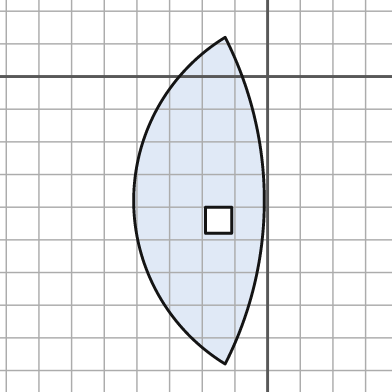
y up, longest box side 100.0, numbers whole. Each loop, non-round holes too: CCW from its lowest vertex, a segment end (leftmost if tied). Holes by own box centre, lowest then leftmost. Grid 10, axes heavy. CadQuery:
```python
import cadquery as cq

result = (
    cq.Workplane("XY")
    .moveTo(-13.0, -88.0)
    .threePointArc((-1.0, -38.0), (-13.0, 12.0))
    .threePointArc((-41.0, -38.0), (-13.0, -88.0))
    .close()
    .moveTo(-19.0, -48.0)
    .lineTo(-11.0, -48.0)
    .lineTo(-11.0, -40.0)
    .lineTo(-19.0, -40.0)
    .close()
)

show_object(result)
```